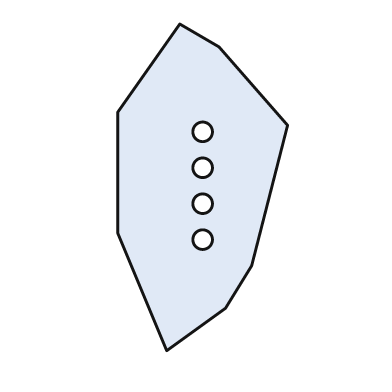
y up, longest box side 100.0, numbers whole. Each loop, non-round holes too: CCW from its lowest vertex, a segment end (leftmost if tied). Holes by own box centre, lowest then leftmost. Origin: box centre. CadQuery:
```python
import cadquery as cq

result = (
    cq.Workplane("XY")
    .moveTo(-11.0, -50.0)
    .lineTo(7.0, -37.0)
    .lineTo(15.0, -24.0)
    .lineTo(26.0, 19.0)
    .lineTo(5.0, 43.0)
    .lineTo(-7.0, 50.0)
    .lineTo(-26.0, 23.0)
    .lineTo(-26.0, -14.0)
    .close()
    .moveTo(0.0, -16.0)
    .circle(3.0)
    .moveTo(0.0, -5.0)
    .circle(3.0)
    .moveTo(0.0, 6.0)
    .circle(3.0)
    .moveTo(0.0, 17.0)
    .circle(3.0)
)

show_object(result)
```